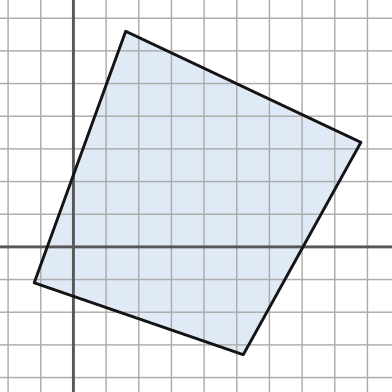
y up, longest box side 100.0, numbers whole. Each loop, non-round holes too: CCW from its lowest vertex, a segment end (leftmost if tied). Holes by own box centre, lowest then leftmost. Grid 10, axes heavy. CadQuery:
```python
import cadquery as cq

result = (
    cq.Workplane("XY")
    .moveTo(52.0, -33.0)
    .lineTo(88.0, 32.0)
    .lineTo(16.0, 66.0)
    .lineTo(-12.0, -11.0)
    .close()
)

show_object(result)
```